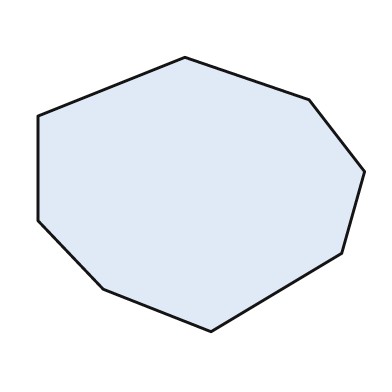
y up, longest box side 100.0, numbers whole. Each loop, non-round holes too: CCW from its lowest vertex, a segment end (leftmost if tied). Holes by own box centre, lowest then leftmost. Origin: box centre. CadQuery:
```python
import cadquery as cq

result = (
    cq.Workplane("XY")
    .moveTo(3.0, -42.0)
    .lineTo(43.0, -18.0)
    .lineTo(50.0, 7.0)
    .lineTo(33.0, 29.0)
    .lineTo(-5.0, 42.0)
    .lineTo(-50.0, 24.0)
    .lineTo(-50.0, -8.0)
    .lineTo(-30.0, -29.0)
    .close()
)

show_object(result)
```